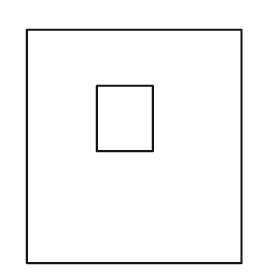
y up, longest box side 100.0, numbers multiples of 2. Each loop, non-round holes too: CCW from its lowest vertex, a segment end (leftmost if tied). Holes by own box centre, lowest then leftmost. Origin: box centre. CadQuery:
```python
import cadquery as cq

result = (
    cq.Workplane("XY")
    .moveTo(-46.0, -50.0)
    .lineTo(46.0, -50.0)
    .lineTo(46.0, 50.0)
    .lineTo(-46.0, 50.0)
    .close()
    .moveTo(-16.0, -2.0)
    .lineTo(8.0, -2.0)
    .lineTo(8.0, 26.0)
    .lineTo(-16.0, 26.0)
    .close()
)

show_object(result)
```